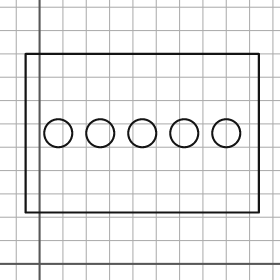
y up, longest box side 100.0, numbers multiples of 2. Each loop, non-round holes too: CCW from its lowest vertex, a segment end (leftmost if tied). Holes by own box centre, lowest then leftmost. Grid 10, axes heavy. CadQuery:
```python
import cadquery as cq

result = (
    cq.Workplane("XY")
    .moveTo(-6.0, 22.0)
    .lineTo(94.0, 22.0)
    .lineTo(94.0, 90.0)
    .lineTo(-6.0, 90.0)
    .close()
    .moveTo(8.0, 56.0)
    .circle(6.0)
    .moveTo(26.0, 56.0)
    .circle(6.0)
    .moveTo(44.0, 56.0)
    .circle(6.0)
    .moveTo(62.0, 56.0)
    .circle(6.0)
    .moveTo(80.0, 56.0)
    .circle(6.0)
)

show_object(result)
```